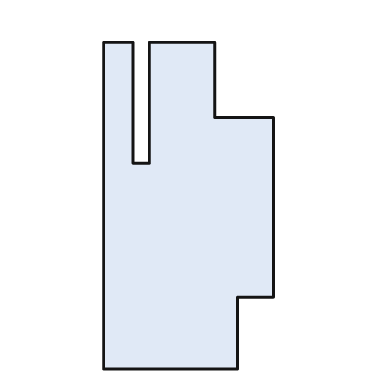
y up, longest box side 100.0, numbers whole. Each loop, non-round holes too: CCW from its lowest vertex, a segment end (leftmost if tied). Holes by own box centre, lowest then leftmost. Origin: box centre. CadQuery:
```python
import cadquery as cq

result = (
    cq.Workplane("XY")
    .moveTo(-26.0, -50.0)
    .lineTo(15.0, -50.0)
    .lineTo(15.0, -28.0)
    .lineTo(26.0, -28.0)
    .lineTo(26.0, 27.0)
    .lineTo(8.0, 27.0)
    .lineTo(8.0, 50.0)
    .lineTo(-12.0, 50.0)
    .lineTo(-12.0, 13.0)
    .lineTo(-17.0, 13.0)
    .lineTo(-17.0, 50.0)
    .lineTo(-26.0, 50.0)
    .close()
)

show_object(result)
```